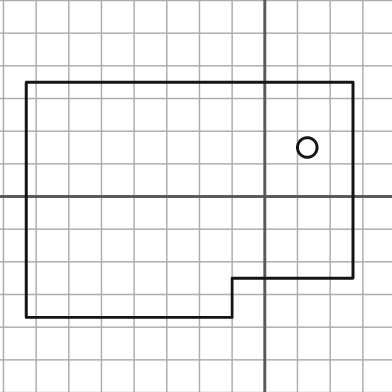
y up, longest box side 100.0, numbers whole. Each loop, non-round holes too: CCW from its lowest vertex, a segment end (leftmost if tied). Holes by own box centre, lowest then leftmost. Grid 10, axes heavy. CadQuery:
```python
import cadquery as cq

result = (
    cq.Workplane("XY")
    .moveTo(-73.0, -37.0)
    .lineTo(-10.0, -37.0)
    .lineTo(-10.0, -25.0)
    .lineTo(27.0, -25.0)
    .lineTo(27.0, 35.0)
    .lineTo(-73.0, 35.0)
    .close()
    .moveTo(13.0, 15.0)
    .circle(3.0)
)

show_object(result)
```